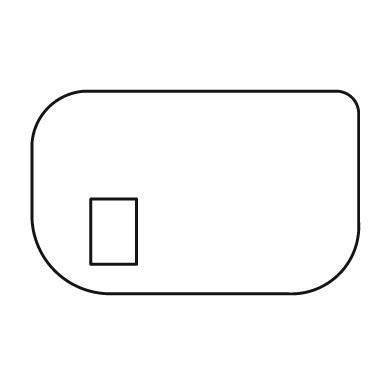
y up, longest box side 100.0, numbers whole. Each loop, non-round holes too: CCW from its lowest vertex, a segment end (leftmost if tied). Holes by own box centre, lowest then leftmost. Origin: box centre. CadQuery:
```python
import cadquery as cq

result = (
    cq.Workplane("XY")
    .moveTo(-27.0, -31.0)
    .lineTo(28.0, -31.0)
    .threePointArc((44.0, -25.0), (50.0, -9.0))
    .lineTo(50.0, 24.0)
    .threePointArc((48.0, 29.0), (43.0, 31.0))
    .lineTo(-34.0, 31.0)
    .threePointArc((-45.0, 26.0), (-50.0, 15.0))
    .lineTo(-50.0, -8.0)
    .threePointArc((-43.0, -24.0), (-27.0, -31.0))
    .close()
    .moveTo(-32.0, -22.0)
    .lineTo(-18.0, -22.0)
    .lineTo(-18.0, -2.0)
    .lineTo(-32.0, -2.0)
    .close()
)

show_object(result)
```